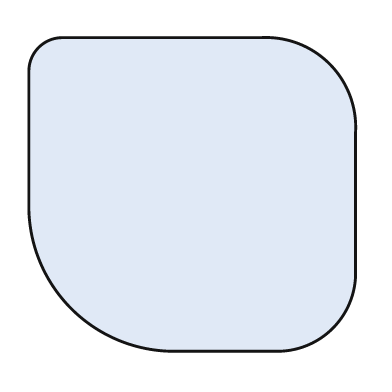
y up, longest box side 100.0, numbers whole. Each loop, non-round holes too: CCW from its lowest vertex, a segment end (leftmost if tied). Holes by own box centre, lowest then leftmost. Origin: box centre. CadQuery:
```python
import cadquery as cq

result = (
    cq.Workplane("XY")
    .moveTo(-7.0, -48.0)
    .lineTo(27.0, -48.0)
    .threePointArc((43.0, -41.0), (50.0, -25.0))
    .lineTo(50.0, 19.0)
    .threePointArc((42.0, 40.0), (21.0, 48.0))
    .lineTo(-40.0, 48.0)
    .threePointArc((-47.0, 45.0), (-50.0, 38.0))
    .lineTo(-50.0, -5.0)
    .threePointArc((-37.0, -35.0), (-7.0, -48.0))
    .close()
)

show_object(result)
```